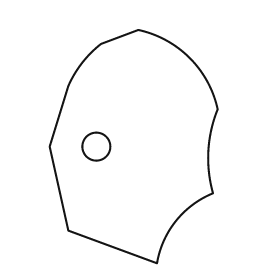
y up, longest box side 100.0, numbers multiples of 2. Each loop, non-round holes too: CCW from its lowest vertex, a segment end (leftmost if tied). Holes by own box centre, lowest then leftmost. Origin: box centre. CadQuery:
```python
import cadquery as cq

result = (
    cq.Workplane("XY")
    .moveTo(10.0, -50.0)
    .threePointArc((18.0, -32.0), (34.0, -20.0))
    .threePointArc((32.0, -2.0), (36.0, 16.0))
    .threePointArc((24.0, 38.0), (2.0, 50.0))
    .lineTo(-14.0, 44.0)
    .threePointArc((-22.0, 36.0), (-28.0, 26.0))
    .lineTo(-36.0, 0.0)
    .lineTo(-28.0, -36.0)
    .close()
    .moveTo(-16.0, 0.0)
    .circle(6.0)
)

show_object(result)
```